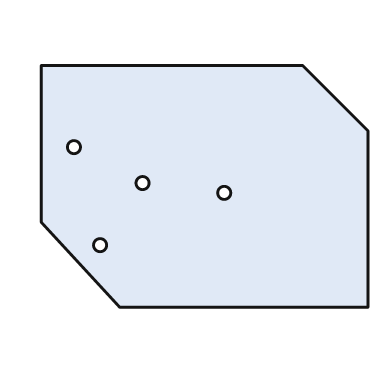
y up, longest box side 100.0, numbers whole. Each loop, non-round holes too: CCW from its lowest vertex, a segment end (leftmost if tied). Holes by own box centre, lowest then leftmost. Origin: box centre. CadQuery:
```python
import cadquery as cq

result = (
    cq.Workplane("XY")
    .moveTo(-26.0, -37.0)
    .lineTo(50.0, -37.0)
    .lineTo(50.0, 17.0)
    .lineTo(30.0, 37.0)
    .lineTo(-50.0, 37.0)
    .lineTo(-50.0, -11.0)
    .close()
    .moveTo(-32.0, -18.0)
    .circle(2.0)
    .moveTo(6.0, -2.0)
    .circle(2.0)
    .moveTo(-19.0, 1.0)
    .circle(2.0)
    .moveTo(-40.0, 12.0)
    .circle(2.0)
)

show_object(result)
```